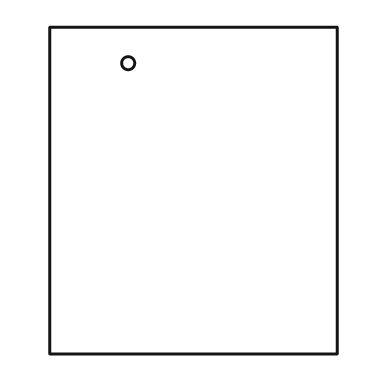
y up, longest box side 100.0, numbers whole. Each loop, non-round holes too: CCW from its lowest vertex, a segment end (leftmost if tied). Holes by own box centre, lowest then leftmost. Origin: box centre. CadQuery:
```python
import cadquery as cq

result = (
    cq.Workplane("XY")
    .moveTo(-44.0, -50.0)
    .lineTo(44.0, -50.0)
    .lineTo(44.0, 50.0)
    .lineTo(-44.0, 50.0)
    .close()
    .moveTo(-20.0, 39.0)
    .circle(2.0)
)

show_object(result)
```